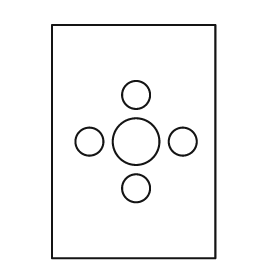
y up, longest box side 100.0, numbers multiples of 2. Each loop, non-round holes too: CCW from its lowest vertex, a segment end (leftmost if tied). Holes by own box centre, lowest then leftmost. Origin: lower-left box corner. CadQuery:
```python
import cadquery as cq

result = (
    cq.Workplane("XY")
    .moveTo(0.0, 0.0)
    .lineTo(70.0, 0.0)
    .lineTo(70.0, 100.0)
    .lineTo(0.0, 100.0)
    .close()
    .moveTo(36.0, 30.0)
    .circle(6.0)
    .moveTo(16.0, 50.0)
    .circle(6.0)
    .moveTo(36.0, 50.0)
    .circle(10.0)
    .moveTo(56.0, 50.0)
    .circle(6.0)
    .moveTo(36.0, 70.0)
    .circle(6.0)
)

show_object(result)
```